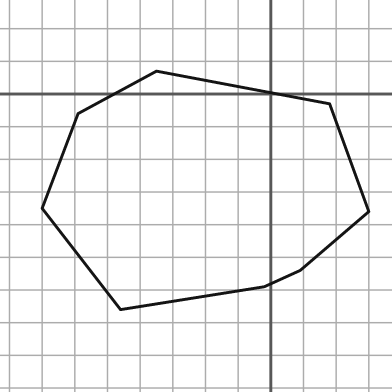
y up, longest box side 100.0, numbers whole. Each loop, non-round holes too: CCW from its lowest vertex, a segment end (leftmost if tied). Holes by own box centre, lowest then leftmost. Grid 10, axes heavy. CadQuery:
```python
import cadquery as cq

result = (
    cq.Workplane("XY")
    .moveTo(-46.0, -66.0)
    .lineTo(-2.0, -59.0)
    .lineTo(9.0, -54.0)
    .lineTo(30.0, -36.0)
    .lineTo(18.0, -3.0)
    .lineTo(-35.0, 7.0)
    .lineTo(-59.0, -6.0)
    .lineTo(-70.0, -35.0)
    .close()
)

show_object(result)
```